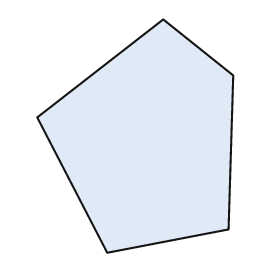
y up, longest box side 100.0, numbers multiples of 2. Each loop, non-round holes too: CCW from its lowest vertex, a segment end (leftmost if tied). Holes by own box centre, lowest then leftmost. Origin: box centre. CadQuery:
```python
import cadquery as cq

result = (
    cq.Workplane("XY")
    .moveTo(-12.0, -50.0)
    .lineTo(40.0, -40.0)
    .lineTo(42.0, 26.0)
    .lineTo(12.0, 50.0)
    .lineTo(-42.0, 8.0)
    .close()
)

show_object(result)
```